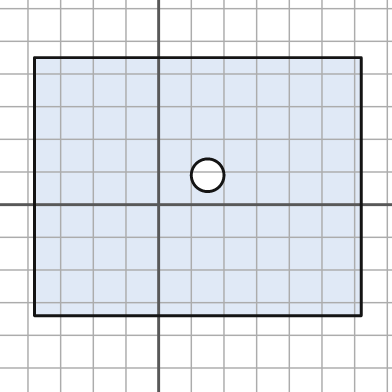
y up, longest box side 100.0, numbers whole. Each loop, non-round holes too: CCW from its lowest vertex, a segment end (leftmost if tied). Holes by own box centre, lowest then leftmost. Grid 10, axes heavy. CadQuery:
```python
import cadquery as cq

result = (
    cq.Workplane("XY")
    .moveTo(-38.0, -34.0)
    .lineTo(62.0, -34.0)
    .lineTo(62.0, 45.0)
    .lineTo(-38.0, 45.0)
    .close()
    .moveTo(15.0, 9.0)
    .circle(5.0)
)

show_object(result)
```